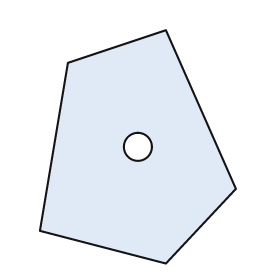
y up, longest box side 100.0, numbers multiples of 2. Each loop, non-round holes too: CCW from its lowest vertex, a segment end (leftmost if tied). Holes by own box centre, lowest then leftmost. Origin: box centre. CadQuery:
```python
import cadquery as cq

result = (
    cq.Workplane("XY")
    .moveTo(12.0, -50.0)
    .lineTo(42.0, -18.0)
    .lineTo(12.0, 50.0)
    .lineTo(-30.0, 36.0)
    .lineTo(-42.0, -36.0)
    .close()
    .moveTo(0.0, 0.0)
    .circle(6.0)
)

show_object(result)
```